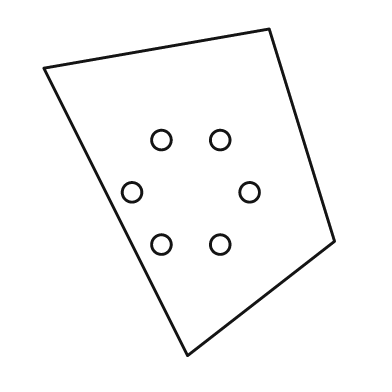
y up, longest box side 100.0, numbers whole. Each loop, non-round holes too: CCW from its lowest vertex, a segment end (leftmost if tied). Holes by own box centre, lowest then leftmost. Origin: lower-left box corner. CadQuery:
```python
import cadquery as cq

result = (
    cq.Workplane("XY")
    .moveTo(44.0, 0.0)
    .lineTo(89.0, 35.0)
    .lineTo(69.0, 100.0)
    .lineTo(0.0, 88.0)
    .close()
    .moveTo(36.0, 34.0)
    .circle(3.0)
    .moveTo(54.0, 34.0)
    .circle(3.0)
    .moveTo(27.0, 50.0)
    .circle(3.0)
    .moveTo(63.0, 50.0)
    .circle(3.0)
    .moveTo(36.0, 66.0)
    .circle(3.0)
    .moveTo(54.0, 66.0)
    .circle(3.0)
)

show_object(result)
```